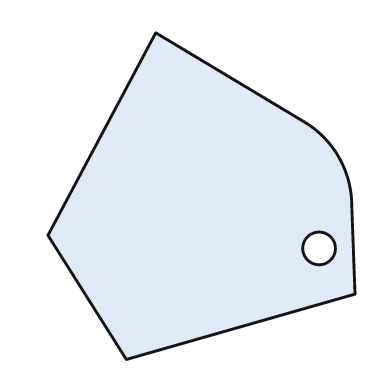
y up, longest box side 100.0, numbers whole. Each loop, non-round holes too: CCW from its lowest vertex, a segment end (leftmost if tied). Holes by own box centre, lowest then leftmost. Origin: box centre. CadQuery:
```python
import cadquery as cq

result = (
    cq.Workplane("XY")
    .moveTo(-23.0, -50.0)
    .lineTo(47.0, -30.0)
    .lineTo(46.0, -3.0)
    .threePointArc((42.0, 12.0), (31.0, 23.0))
    .lineTo(-14.0, 50.0)
    .lineTo(-47.0, -12.0)
    .close()
    .moveTo(36.0, -16.0)
    .circle(5.0)
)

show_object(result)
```